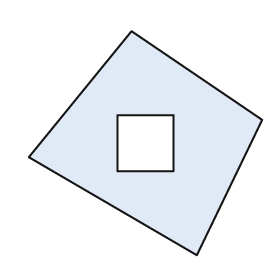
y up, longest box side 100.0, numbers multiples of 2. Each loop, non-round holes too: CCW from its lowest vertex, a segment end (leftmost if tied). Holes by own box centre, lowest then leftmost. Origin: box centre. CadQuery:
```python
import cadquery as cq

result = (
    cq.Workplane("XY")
    .moveTo(22.0, -48.0)
    .lineTo(50.0, 10.0)
    .lineTo(-6.0, 48.0)
    .lineTo(-50.0, -6.0)
    .close()
    .moveTo(-12.0, -12.0)
    .lineTo(12.0, -12.0)
    .lineTo(12.0, 12.0)
    .lineTo(-12.0, 12.0)
    .close()
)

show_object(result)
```